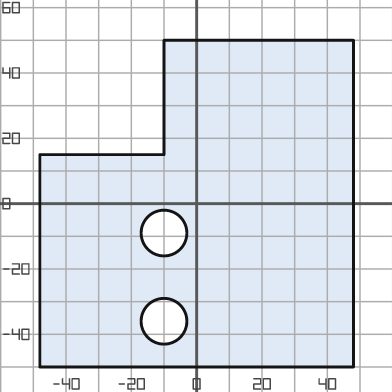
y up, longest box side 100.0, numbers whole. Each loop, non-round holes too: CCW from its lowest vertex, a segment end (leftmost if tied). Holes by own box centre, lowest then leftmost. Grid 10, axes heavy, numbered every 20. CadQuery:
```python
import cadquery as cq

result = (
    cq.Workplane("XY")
    .moveTo(-48.0, -50.0)
    .lineTo(48.0, -50.0)
    .lineTo(48.0, 50.0)
    .lineTo(-10.0, 50.0)
    .lineTo(-10.0, 15.0)
    .lineTo(-48.0, 15.0)
    .close()
    .moveTo(-10.0, -36.0)
    .circle(7.0)
    .moveTo(-10.0, -9.0)
    .circle(7.0)
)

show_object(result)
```